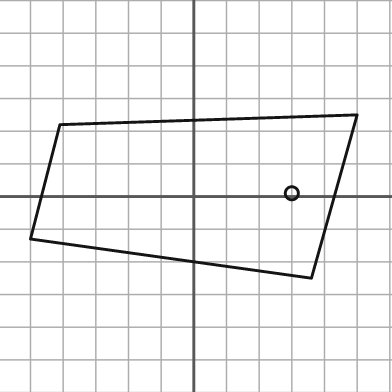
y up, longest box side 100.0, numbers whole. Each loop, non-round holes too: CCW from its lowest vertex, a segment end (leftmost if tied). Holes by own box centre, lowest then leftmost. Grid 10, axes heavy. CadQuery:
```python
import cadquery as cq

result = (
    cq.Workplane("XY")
    .moveTo(36.0, -25.0)
    .lineTo(50.0, 25.0)
    .lineTo(-41.0, 22.0)
    .lineTo(-50.0, -13.0)
    .close()
    .moveTo(30.0, 1.0)
    .circle(2.0)
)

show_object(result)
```